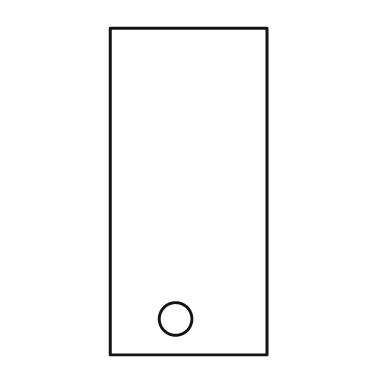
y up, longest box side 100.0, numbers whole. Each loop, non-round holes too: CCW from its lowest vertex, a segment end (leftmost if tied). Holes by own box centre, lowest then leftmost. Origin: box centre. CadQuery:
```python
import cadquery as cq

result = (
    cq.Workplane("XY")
    .moveTo(-24.0, -50.0)
    .lineTo(24.0, -50.0)
    .lineTo(24.0, 50.0)
    .lineTo(-24.0, 50.0)
    .close()
    .moveTo(-4.0, -39.0)
    .circle(5.0)
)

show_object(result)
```